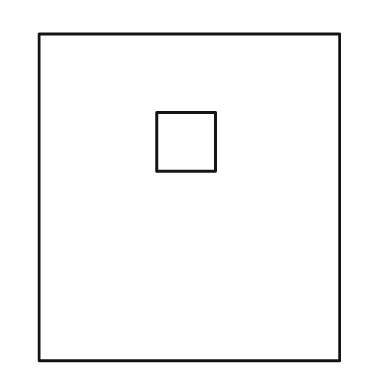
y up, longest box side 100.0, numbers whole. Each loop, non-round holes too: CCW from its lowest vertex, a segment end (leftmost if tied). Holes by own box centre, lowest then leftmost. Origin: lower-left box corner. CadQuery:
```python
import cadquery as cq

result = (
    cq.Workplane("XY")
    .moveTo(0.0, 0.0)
    .lineTo(92.0, 0.0)
    .lineTo(92.0, 100.0)
    .lineTo(0.0, 100.0)
    .close()
    .moveTo(36.0, 58.0)
    .lineTo(54.0, 58.0)
    .lineTo(54.0, 76.0)
    .lineTo(36.0, 76.0)
    .close()
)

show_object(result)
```